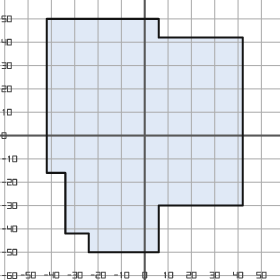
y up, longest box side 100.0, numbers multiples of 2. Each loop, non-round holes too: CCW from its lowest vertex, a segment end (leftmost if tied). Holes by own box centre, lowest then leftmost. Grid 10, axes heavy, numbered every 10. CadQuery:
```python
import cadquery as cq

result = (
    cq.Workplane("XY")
    .moveTo(-24.0, -50.0)
    .lineTo(6.0, -50.0)
    .lineTo(6.0, -30.0)
    .lineTo(42.0, -30.0)
    .lineTo(42.0, 42.0)
    .lineTo(6.0, 42.0)
    .lineTo(6.0, 50.0)
    .lineTo(-42.0, 50.0)
    .lineTo(-42.0, -16.0)
    .lineTo(-34.0, -16.0)
    .lineTo(-34.0, -42.0)
    .lineTo(-24.0, -42.0)
    .close()
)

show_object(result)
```